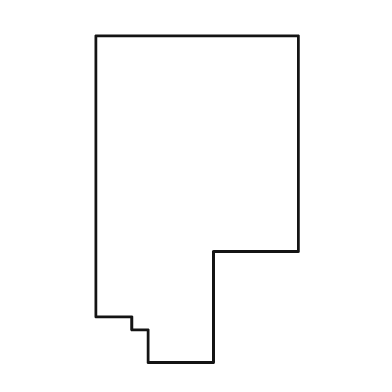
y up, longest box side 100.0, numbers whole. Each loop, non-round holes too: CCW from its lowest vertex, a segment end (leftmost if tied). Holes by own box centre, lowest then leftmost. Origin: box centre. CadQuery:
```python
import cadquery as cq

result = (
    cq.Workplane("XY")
    .moveTo(-15.0, -50.0)
    .lineTo(5.0, -50.0)
    .lineTo(5.0, -16.0)
    .lineTo(31.0, -16.0)
    .lineTo(31.0, 50.0)
    .lineTo(-31.0, 50.0)
    .lineTo(-31.0, -36.0)
    .lineTo(-20.0, -36.0)
    .lineTo(-20.0, -40.0)
    .lineTo(-15.0, -40.0)
    .close()
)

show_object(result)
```